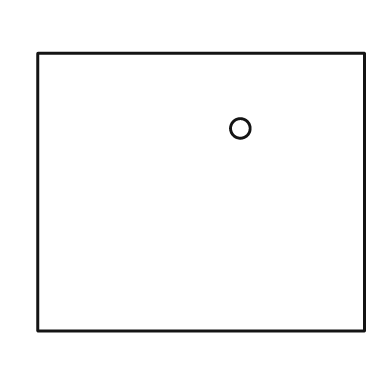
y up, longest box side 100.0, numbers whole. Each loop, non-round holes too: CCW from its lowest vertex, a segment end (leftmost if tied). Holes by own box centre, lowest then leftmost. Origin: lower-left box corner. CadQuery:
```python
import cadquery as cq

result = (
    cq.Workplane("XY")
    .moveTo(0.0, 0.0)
    .lineTo(100.0, 0.0)
    .lineTo(100.0, 85.0)
    .lineTo(0.0, 85.0)
    .close()
    .moveTo(62.0, 62.0)
    .circle(3.0)
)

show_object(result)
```